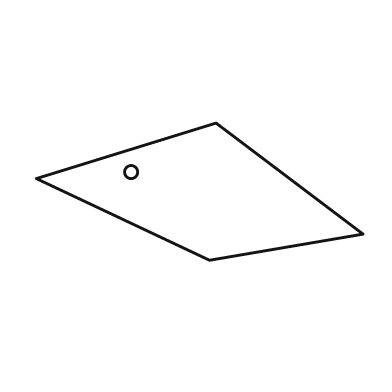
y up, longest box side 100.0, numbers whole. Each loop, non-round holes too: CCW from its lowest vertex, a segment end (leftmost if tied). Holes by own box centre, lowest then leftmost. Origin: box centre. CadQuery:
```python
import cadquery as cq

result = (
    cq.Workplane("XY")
    .moveTo(3.0, -21.0)
    .lineTo(50.0, -13.0)
    .lineTo(5.0, 21.0)
    .lineTo(-50.0, 4.0)
    .close()
    .moveTo(-21.0, 6.0)
    .circle(2.0)
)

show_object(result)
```